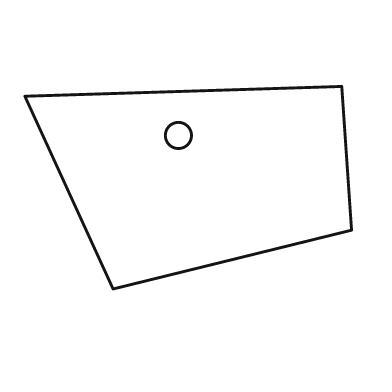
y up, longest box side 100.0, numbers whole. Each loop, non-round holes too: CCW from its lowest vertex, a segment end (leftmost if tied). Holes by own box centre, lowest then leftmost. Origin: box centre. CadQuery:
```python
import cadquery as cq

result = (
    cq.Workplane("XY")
    .moveTo(-23.0, -31.0)
    .lineTo(50.0, -13.0)
    .lineTo(47.0, 31.0)
    .lineTo(-50.0, 28.0)
    .close()
    .moveTo(-3.0, 16.0)
    .circle(4.0)
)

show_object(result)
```